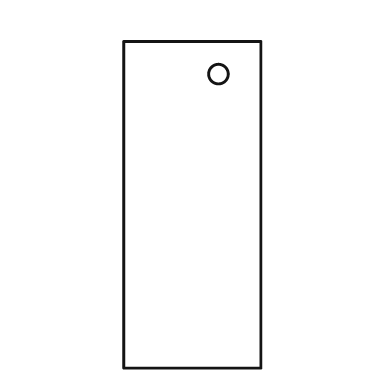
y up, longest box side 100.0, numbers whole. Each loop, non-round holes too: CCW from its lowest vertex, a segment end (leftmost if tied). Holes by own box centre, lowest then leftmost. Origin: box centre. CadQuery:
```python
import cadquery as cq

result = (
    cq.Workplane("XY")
    .moveTo(-21.0, -50.0)
    .lineTo(21.0, -50.0)
    .lineTo(21.0, 50.0)
    .lineTo(-21.0, 50.0)
    .close()
    .moveTo(8.0, 40.0)
    .circle(3.0)
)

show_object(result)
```